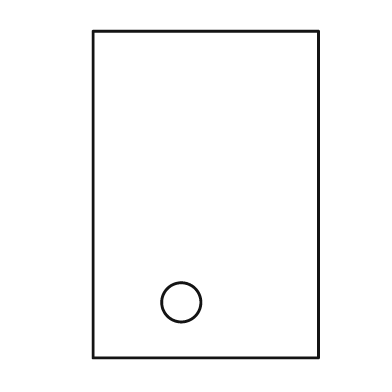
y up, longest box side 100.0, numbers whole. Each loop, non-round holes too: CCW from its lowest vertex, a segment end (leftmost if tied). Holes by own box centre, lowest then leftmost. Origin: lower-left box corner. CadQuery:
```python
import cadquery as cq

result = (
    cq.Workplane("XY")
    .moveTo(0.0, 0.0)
    .lineTo(69.0, 0.0)
    .lineTo(69.0, 100.0)
    .lineTo(0.0, 100.0)
    .close()
    .moveTo(27.0, 17.0)
    .circle(6.0)
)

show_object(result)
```